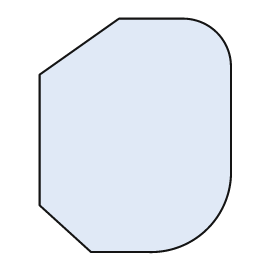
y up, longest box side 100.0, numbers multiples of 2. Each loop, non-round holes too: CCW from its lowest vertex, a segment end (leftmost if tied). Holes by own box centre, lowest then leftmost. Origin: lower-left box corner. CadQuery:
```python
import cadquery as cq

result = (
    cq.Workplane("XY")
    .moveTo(22.0, 0.0)
    .lineTo(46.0, 0.0)
    .threePointArc((72.0, 10.0), (82.0, 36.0))
    .lineTo(82.0, 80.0)
    .threePointArc((76.0, 94.0), (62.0, 100.0))
    .lineTo(34.0, 100.0)
    .lineTo(0.0, 76.0)
    .lineTo(0.0, 20.0)
    .close()
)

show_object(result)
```